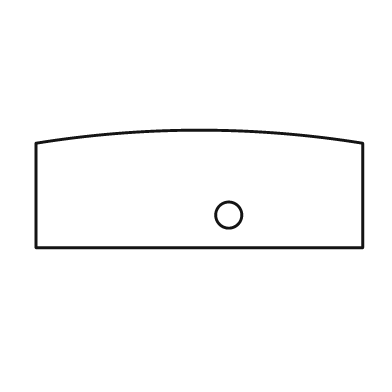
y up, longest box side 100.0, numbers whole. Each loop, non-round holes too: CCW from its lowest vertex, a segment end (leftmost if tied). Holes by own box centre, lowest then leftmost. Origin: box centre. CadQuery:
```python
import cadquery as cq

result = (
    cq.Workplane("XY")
    .moveTo(-50.0, -18.0)
    .lineTo(50.0, -18.0)
    .lineTo(50.0, 14.0)
    .threePointArc((0.0, 18.0), (-50.0, 14.0))
    .close()
    .moveTo(9.0, -8.0)
    .circle(4.0)
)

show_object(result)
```